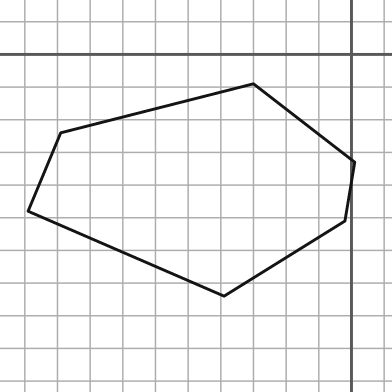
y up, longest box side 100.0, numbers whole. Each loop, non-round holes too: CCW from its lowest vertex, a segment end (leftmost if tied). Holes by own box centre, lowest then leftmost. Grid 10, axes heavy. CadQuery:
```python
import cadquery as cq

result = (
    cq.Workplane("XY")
    .moveTo(-39.0, -74.0)
    .lineTo(-2.0, -51.0)
    .lineTo(1.0, -33.0)
    .lineTo(-30.0, -9.0)
    .lineTo(-89.0, -24.0)
    .lineTo(-99.0, -48.0)
    .close()
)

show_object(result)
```